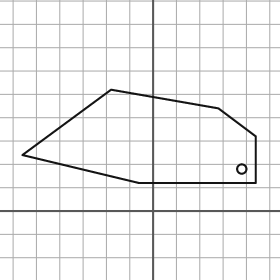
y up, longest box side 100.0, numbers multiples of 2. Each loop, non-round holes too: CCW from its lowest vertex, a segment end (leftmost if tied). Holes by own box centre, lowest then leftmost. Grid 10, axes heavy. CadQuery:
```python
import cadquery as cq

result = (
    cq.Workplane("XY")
    .moveTo(-6.0, 12.0)
    .lineTo(44.0, 12.0)
    .lineTo(44.0, 32.0)
    .lineTo(28.0, 44.0)
    .lineTo(-18.0, 52.0)
    .lineTo(-56.0, 24.0)
    .close()
    .moveTo(38.0, 18.0)
    .circle(2.0)
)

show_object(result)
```